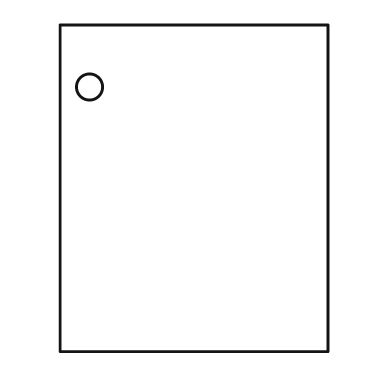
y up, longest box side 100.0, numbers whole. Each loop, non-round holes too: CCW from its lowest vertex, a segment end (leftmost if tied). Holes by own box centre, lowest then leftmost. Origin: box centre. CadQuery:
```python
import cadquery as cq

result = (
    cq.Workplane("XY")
    .moveTo(-41.0, -50.0)
    .lineTo(41.0, -50.0)
    .lineTo(41.0, 50.0)
    .lineTo(-41.0, 50.0)
    .close()
    .moveTo(-32.0, 31.0)
    .circle(4.0)
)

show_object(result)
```